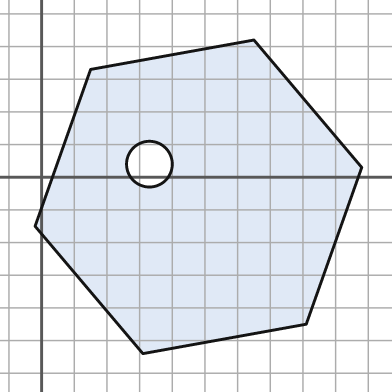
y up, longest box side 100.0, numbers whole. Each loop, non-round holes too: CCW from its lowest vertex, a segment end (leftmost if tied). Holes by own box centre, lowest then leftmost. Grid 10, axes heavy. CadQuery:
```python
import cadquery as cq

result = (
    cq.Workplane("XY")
    .moveTo(31.0, -54.0)
    .lineTo(81.0, -45.0)
    .lineTo(98.0, 3.0)
    .lineTo(65.0, 42.0)
    .lineTo(15.0, 33.0)
    .lineTo(-2.0, -15.0)
    .close()
    .moveTo(33.0, 4.0)
    .circle(7.0)
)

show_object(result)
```